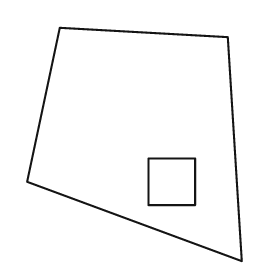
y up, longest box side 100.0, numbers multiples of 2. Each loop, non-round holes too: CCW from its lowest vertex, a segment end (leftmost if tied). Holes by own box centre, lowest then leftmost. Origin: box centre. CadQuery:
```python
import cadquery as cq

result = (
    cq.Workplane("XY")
    .moveTo(46.0, -50.0)
    .lineTo(40.0, 46.0)
    .lineTo(-32.0, 50.0)
    .lineTo(-46.0, -16.0)
    .close()
    .moveTo(6.0, -26.0)
    .lineTo(26.0, -26.0)
    .lineTo(26.0, -6.0)
    .lineTo(6.0, -6.0)
    .close()
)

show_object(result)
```